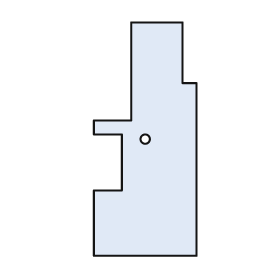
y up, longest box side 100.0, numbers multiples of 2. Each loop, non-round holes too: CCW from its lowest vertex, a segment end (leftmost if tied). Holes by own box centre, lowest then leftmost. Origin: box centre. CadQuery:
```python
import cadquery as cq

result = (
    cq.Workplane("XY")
    .moveTo(-22.0, -50.0)
    .lineTo(22.0, -50.0)
    .lineTo(22.0, 24.0)
    .lineTo(16.0, 24.0)
    .lineTo(16.0, 50.0)
    .lineTo(-6.0, 50.0)
    .lineTo(-6.0, 8.0)
    .lineTo(-22.0, 8.0)
    .lineTo(-22.0, 2.0)
    .lineTo(-10.0, 2.0)
    .lineTo(-10.0, -22.0)
    .lineTo(-22.0, -22.0)
    .close()
    .moveTo(0.0, 0.0)
    .circle(2.0)
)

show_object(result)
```